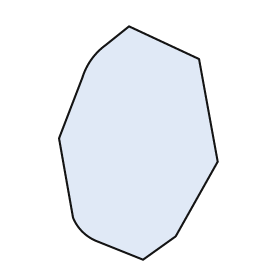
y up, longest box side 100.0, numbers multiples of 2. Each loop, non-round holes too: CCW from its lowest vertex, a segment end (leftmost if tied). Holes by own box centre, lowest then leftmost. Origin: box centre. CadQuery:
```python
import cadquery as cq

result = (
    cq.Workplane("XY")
    .moveTo(2.0, -50.0)
    .lineTo(16.0, -40.0)
    .lineTo(34.0, -8.0)
    .lineTo(26.0, 36.0)
    .lineTo(-4.0, 50.0)
    .lineTo(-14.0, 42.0)
    .threePointArc((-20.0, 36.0), (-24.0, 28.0))
    .lineTo(-34.0, 2.0)
    .lineTo(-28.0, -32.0)
    .threePointArc((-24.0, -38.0), (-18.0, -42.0))
    .close()
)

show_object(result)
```